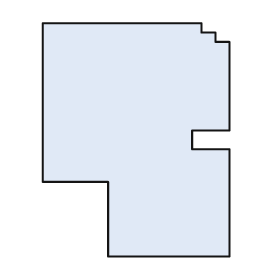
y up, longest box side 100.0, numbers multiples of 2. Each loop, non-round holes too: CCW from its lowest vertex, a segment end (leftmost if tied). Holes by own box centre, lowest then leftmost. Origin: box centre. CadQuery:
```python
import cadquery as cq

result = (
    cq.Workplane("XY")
    .moveTo(-12.0, -50.0)
    .lineTo(40.0, -50.0)
    .lineTo(40.0, -4.0)
    .lineTo(24.0, -4.0)
    .lineTo(24.0, 4.0)
    .lineTo(40.0, 4.0)
    .lineTo(40.0, 42.0)
    .lineTo(34.0, 42.0)
    .lineTo(34.0, 46.0)
    .lineTo(28.0, 46.0)
    .lineTo(28.0, 50.0)
    .lineTo(-40.0, 50.0)
    .lineTo(-40.0, -18.0)
    .lineTo(-12.0, -18.0)
    .close()
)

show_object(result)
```